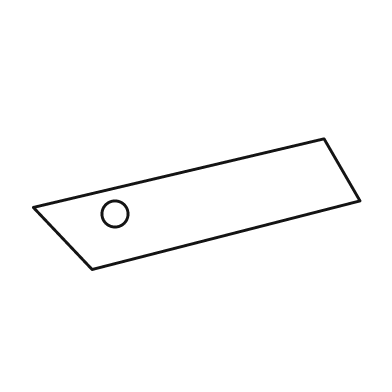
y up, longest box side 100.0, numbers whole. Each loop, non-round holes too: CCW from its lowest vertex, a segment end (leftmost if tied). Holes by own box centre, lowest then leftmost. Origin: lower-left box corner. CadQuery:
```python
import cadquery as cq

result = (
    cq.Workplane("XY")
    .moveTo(18.0, 0.0)
    .lineTo(100.0, 21.0)
    .lineTo(89.0, 40.0)
    .lineTo(0.0, 19.0)
    .close()
    .moveTo(25.0, 17.0)
    .circle(4.0)
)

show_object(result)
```